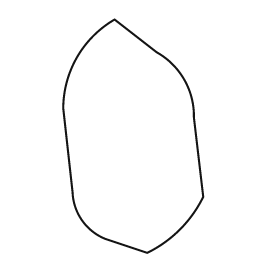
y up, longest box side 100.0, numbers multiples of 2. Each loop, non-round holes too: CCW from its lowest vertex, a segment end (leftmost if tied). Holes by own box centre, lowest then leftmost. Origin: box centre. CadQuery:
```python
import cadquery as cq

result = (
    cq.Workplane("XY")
    .moveTo(6.0, -50.0)
    .threePointArc((20.0, -40.0), (30.0, -26.0))
    .lineTo(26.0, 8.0)
    .threePointArc((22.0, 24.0), (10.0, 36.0))
    .lineTo(-8.0, 50.0)
    .threePointArc((-24.0, 34.0), (-30.0, 12.0))
    .lineTo(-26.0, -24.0)
    .threePointArc((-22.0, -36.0), (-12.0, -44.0))
    .close()
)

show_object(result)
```